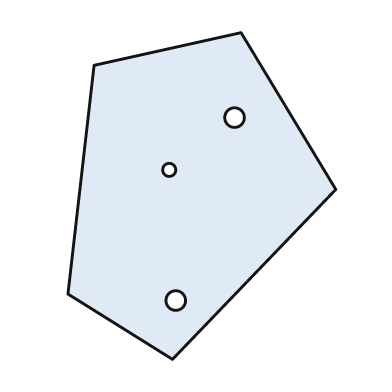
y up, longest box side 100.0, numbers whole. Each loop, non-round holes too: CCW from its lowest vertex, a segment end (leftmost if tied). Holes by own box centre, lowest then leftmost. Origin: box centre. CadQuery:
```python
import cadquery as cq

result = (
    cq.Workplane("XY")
    .moveTo(-9.0, -50.0)
    .lineTo(41.0, 2.0)
    .lineTo(12.0, 50.0)
    .lineTo(-33.0, 40.0)
    .lineTo(-41.0, -30.0)
    .close()
    .moveTo(-8.0, -32.0)
    .circle(3.0)
    .moveTo(-10.0, 8.0)
    .circle(2.0)
    .moveTo(10.0, 24.0)
    .circle(3.0)
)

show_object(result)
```